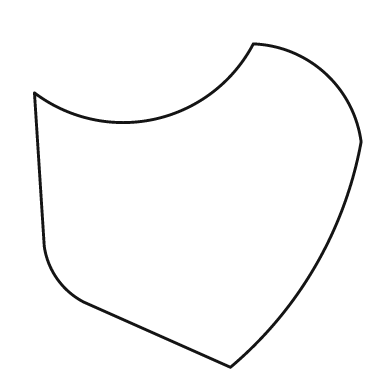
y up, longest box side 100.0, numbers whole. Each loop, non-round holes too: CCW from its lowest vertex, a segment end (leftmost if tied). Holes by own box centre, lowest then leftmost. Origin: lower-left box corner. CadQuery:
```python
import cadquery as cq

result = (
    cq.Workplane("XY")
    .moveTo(60.0, 0.0)
    .threePointArc((86.0, 31.0), (100.0, 69.0))
    .threePointArc((89.0, 90.0), (67.0, 99.0))
    .threePointArc((37.0, 76.0), (0.0, 84.0))
    .lineTo(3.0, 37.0)
    .threePointArc((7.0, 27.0), (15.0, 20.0))
    .close()
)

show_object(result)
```